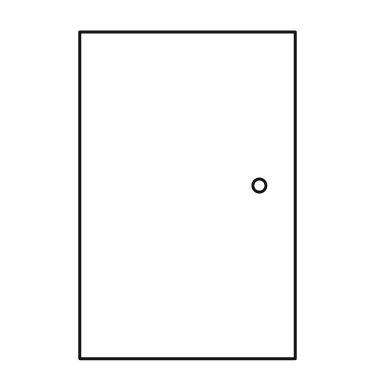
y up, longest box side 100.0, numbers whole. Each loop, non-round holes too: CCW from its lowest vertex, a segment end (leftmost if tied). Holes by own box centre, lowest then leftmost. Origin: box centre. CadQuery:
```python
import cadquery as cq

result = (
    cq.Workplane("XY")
    .moveTo(-33.0, -50.0)
    .lineTo(33.0, -50.0)
    .lineTo(33.0, 50.0)
    .lineTo(-33.0, 50.0)
    .close()
    .moveTo(22.0, 3.0)
    .circle(2.0)
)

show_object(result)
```